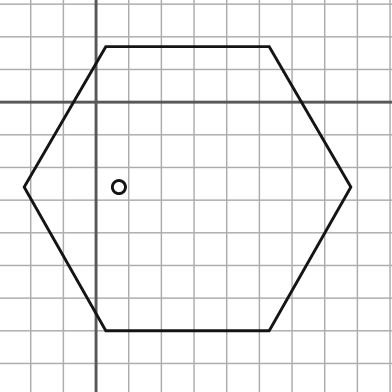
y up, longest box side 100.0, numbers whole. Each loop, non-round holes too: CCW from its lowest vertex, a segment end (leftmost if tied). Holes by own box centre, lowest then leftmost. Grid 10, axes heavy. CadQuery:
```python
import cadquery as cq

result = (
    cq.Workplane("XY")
    .moveTo(3.0, -70.0)
    .lineTo(53.0, -70.0)
    .lineTo(78.0, -26.0)
    .lineTo(53.0, 17.0)
    .lineTo(3.0, 17.0)
    .lineTo(-22.0, -26.0)
    .close()
    .moveTo(7.0, -26.0)
    .circle(2.0)
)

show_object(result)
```